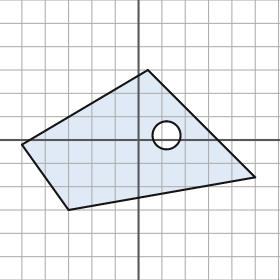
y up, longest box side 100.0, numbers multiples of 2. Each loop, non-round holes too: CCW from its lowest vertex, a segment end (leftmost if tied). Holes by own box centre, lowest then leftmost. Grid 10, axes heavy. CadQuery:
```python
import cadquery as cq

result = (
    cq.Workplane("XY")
    .moveTo(-30.0, -30.0)
    .lineTo(50.0, -16.0)
    .lineTo(4.0, 30.0)
    .lineTo(-50.0, -2.0)
    .close()
    .moveTo(12.0, 2.0)
    .circle(6.0)
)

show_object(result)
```